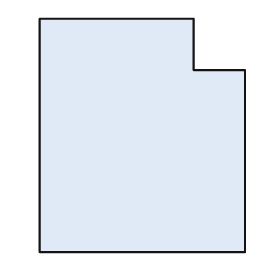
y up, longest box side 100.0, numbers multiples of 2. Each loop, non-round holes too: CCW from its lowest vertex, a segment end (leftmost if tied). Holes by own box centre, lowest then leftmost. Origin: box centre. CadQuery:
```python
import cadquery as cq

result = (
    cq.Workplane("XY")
    .moveTo(-44.0, -50.0)
    .lineTo(44.0, -50.0)
    .lineTo(44.0, 28.0)
    .lineTo(22.0, 28.0)
    .lineTo(22.0, 50.0)
    .lineTo(-44.0, 50.0)
    .close()
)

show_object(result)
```